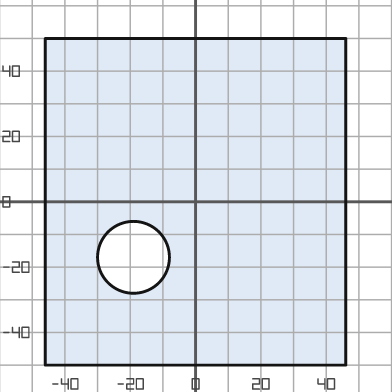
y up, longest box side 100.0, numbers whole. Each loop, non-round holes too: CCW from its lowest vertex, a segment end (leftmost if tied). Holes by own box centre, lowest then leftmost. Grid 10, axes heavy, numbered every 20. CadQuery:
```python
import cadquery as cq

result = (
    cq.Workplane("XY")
    .moveTo(-46.0, -50.0)
    .lineTo(46.0, -50.0)
    .lineTo(46.0, 50.0)
    .lineTo(-46.0, 50.0)
    .close()
    .moveTo(-19.0, -17.0)
    .circle(11.0)
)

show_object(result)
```